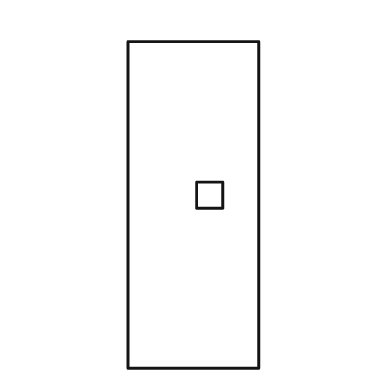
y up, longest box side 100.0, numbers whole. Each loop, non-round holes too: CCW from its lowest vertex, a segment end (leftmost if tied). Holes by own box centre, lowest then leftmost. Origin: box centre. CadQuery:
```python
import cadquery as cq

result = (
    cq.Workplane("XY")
    .moveTo(-20.0, -50.0)
    .lineTo(20.0, -50.0)
    .lineTo(20.0, 50.0)
    .lineTo(-20.0, 50.0)
    .close()
    .moveTo(1.0, -1.0)
    .lineTo(9.0, -1.0)
    .lineTo(9.0, 7.0)
    .lineTo(1.0, 7.0)
    .close()
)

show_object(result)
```